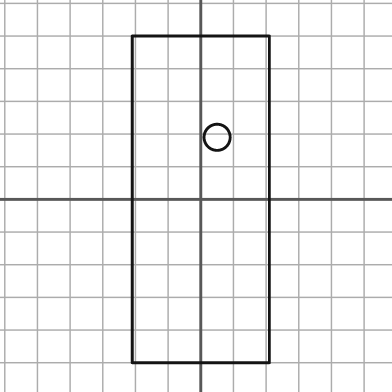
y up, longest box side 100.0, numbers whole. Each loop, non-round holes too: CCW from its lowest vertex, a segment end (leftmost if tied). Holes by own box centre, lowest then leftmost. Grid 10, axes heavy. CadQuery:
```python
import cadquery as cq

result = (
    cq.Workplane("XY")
    .moveTo(-21.0, -50.0)
    .lineTo(21.0, -50.0)
    .lineTo(21.0, 50.0)
    .lineTo(-21.0, 50.0)
    .close()
    .moveTo(5.0, 19.0)
    .circle(4.0)
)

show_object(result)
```